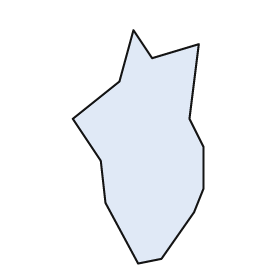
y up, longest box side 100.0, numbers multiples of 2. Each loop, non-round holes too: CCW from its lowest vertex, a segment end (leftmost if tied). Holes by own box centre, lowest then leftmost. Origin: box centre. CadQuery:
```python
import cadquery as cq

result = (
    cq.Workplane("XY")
    .moveTo(0.0, -50.0)
    .lineTo(10.0, -48.0)
    .lineTo(24.0, -28.0)
    .lineTo(28.0, -18.0)
    .lineTo(28.0, 0.0)
    .lineTo(22.0, 12.0)
    .lineTo(26.0, 44.0)
    .lineTo(6.0, 38.0)
    .lineTo(-2.0, 50.0)
    .lineTo(-8.0, 28.0)
    .lineTo(-28.0, 12.0)
    .lineTo(-16.0, -6.0)
    .lineTo(-14.0, -24.0)
    .close()
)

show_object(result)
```